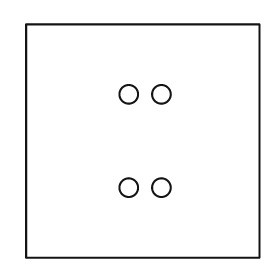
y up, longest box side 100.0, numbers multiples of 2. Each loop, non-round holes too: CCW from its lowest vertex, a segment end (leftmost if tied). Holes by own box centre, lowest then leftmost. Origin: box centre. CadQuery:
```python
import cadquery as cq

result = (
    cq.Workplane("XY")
    .moveTo(-50.0, -50.0)
    .lineTo(50.0, -50.0)
    .lineTo(50.0, 50.0)
    .lineTo(-50.0, 50.0)
    .close()
    .moveTo(-6.0, -20.0)
    .circle(4.0)
    .moveTo(8.0, -20.0)
    .circle(4.0)
    .moveTo(-6.0, 20.0)
    .circle(4.0)
    .moveTo(8.0, 20.0)
    .circle(4.0)
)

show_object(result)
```